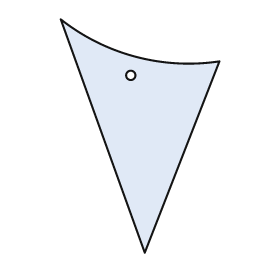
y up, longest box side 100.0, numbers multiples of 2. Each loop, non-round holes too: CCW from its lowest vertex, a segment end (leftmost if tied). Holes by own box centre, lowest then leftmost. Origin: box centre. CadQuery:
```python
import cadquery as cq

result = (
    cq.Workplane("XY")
    .moveTo(2.0, -50.0)
    .lineTo(34.0, 32.0)
    .threePointArc((-2.0, 34.0), (-34.0, 50.0))
    .close()
    .moveTo(-4.0, 26.0)
    .circle(2.0)
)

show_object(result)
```